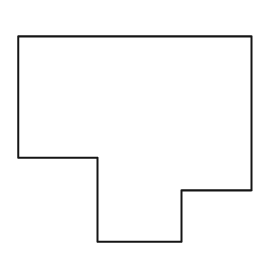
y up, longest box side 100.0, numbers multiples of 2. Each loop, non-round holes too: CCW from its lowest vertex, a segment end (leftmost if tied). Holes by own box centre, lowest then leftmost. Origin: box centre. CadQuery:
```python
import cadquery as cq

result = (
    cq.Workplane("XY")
    .moveTo(-16.0, -44.0)
    .lineTo(20.0, -44.0)
    .lineTo(20.0, -22.0)
    .lineTo(50.0, -22.0)
    .lineTo(50.0, 44.0)
    .lineTo(-50.0, 44.0)
    .lineTo(-50.0, -8.0)
    .lineTo(-16.0, -8.0)
    .close()
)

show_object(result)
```